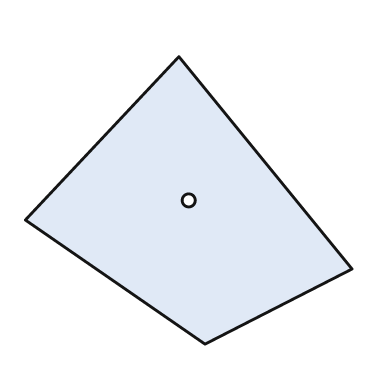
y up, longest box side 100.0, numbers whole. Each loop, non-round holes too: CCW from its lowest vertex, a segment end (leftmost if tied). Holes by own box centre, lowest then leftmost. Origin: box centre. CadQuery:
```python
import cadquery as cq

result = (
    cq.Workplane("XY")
    .moveTo(5.0, -44.0)
    .lineTo(50.0, -21.0)
    .lineTo(-3.0, 44.0)
    .lineTo(-50.0, -6.0)
    .close()
    .moveTo(0.0, 0.0)
    .circle(2.0)
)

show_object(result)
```